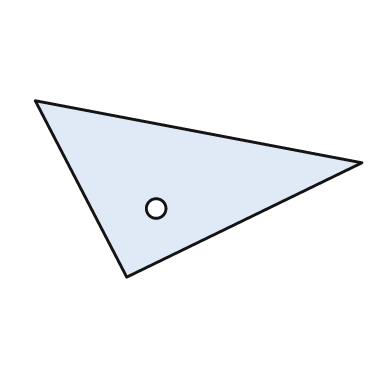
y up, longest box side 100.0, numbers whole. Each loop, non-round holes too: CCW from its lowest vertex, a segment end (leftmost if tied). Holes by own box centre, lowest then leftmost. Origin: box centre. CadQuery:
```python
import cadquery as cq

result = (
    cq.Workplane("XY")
    .moveTo(-22.0, -27.0)
    .lineTo(50.0, 8.0)
    .lineTo(-50.0, 27.0)
    .close()
    .moveTo(-13.0, -6.0)
    .circle(3.0)
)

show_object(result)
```